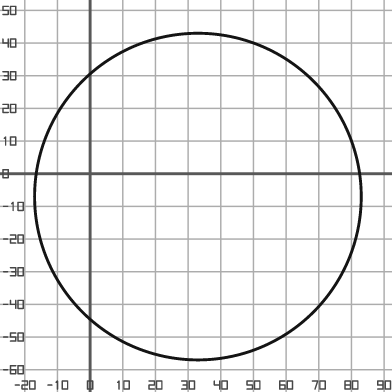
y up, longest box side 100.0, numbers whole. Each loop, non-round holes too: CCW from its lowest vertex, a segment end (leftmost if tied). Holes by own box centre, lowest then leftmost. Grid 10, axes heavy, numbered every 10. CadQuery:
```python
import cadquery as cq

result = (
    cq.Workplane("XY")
    .moveTo(33.0, -7.0)
    .circle(50.0)
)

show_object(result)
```